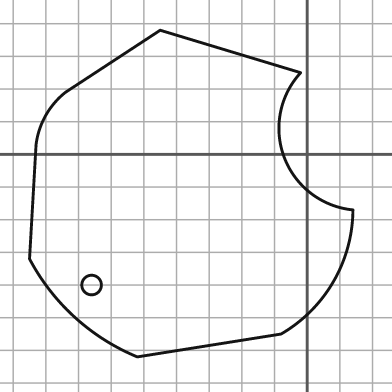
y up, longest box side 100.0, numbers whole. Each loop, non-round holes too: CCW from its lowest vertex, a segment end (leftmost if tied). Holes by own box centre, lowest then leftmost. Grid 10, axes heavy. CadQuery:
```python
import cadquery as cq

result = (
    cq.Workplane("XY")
    .moveTo(-52.0, -62.0)
    .lineTo(-8.0, -55.0)
    .threePointArc((8.0, -39.0), (14.0, -17.0))
    .threePointArc((-7.0, -1.0), (-2.0, 25.0))
    .lineTo(-45.0, 38.0)
    .lineTo(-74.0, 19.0)
    .threePointArc((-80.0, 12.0), (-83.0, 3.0))
    .lineTo(-85.0, -32.0)
    .threePointArc((-71.0, -50.0), (-52.0, -62.0))
    .close()
    .moveTo(-66.0, -40.0)
    .circle(3.0)
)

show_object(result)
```